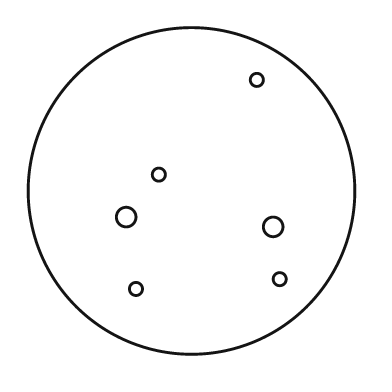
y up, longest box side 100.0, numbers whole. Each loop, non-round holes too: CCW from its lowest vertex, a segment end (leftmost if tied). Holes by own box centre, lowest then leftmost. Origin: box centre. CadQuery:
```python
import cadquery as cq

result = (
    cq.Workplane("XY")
    .moveTo(0.0, 0.0)
    .circle(50.0)
    .moveTo(-17.0, -30.0)
    .circle(2.0)
    .moveTo(27.0, -27.0)
    .circle(2.0)
    .moveTo(25.0, -11.0)
    .circle(3.0)
    .moveTo(-20.0, -8.0)
    .circle(3.0)
    .moveTo(-10.0, 5.0)
    .circle(2.0)
    .moveTo(20.0, 34.0)
    .circle(2.0)
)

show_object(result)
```